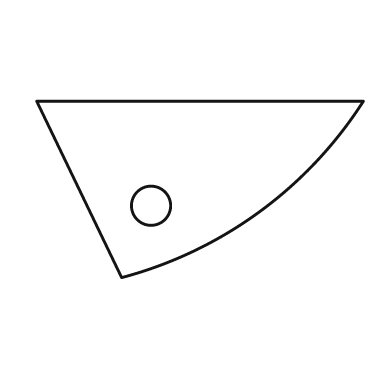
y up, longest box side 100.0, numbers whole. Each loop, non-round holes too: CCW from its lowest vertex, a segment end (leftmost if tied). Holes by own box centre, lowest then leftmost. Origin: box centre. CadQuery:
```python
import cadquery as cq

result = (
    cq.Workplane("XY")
    .moveTo(-24.0, -27.0)
    .threePointArc((18.0, -7.0), (50.0, 27.0))
    .lineTo(-50.0, 27.0)
    .close()
    .moveTo(-15.0, -5.0)
    .circle(6.0)
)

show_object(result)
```